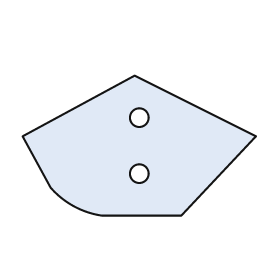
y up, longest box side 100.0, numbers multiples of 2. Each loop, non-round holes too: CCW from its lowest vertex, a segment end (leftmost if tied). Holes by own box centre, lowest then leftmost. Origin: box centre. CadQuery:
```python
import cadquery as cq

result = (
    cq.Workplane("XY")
    .moveTo(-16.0, -30.0)
    .lineTo(18.0, -30.0)
    .lineTo(50.0, 4.0)
    .lineTo(-2.0, 30.0)
    .lineTo(-50.0, 4.0)
    .lineTo(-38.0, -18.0)
    .threePointArc((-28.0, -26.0), (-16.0, -30.0))
    .close()
    .moveTo(0.0, -12.0)
    .circle(4.0)
    .moveTo(0.0, 12.0)
    .circle(4.0)
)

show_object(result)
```